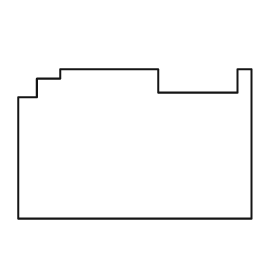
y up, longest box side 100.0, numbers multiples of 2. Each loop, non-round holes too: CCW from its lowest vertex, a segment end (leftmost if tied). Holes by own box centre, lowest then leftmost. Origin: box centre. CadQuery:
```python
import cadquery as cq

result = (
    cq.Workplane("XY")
    .moveTo(-50.0, -32.0)
    .lineTo(50.0, -32.0)
    .lineTo(50.0, 32.0)
    .lineTo(44.0, 32.0)
    .lineTo(44.0, 22.0)
    .lineTo(10.0, 22.0)
    .lineTo(10.0, 32.0)
    .lineTo(-32.0, 32.0)
    .lineTo(-32.0, 28.0)
    .lineTo(-42.0, 28.0)
    .lineTo(-42.0, 20.0)
    .lineTo(-50.0, 20.0)
    .close()
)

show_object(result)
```